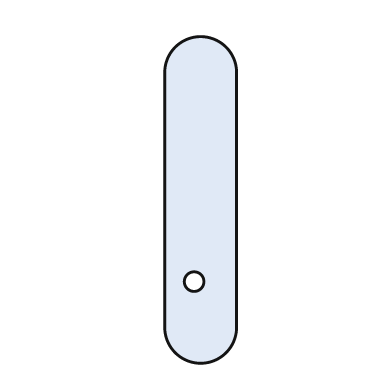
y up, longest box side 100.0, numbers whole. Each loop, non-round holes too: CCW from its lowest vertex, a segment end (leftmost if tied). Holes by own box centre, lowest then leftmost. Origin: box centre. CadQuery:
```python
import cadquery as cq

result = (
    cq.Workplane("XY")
    .moveTo(-11.0, -39.0)
    .threePointArc((0.0, -50.0), (11.0, -39.0))
    .lineTo(11.0, 39.0)
    .threePointArc((0.0, 50.0), (-11.0, 39.0))
    .close()
    .moveTo(-2.0, -25.0)
    .circle(3.0)
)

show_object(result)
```